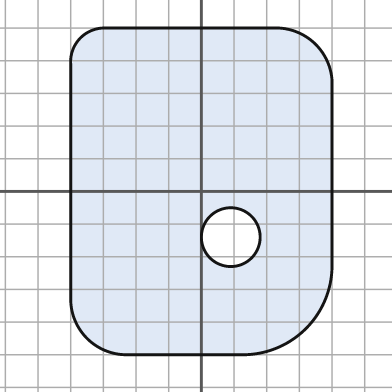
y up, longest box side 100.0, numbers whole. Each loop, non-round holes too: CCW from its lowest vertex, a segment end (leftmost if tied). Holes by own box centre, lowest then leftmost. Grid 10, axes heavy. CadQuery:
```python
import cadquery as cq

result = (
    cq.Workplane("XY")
    .moveTo(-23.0, -50.0)
    .lineTo(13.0, -50.0)
    .threePointArc((32.0, -42.0), (40.0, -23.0))
    .lineTo(40.0, 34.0)
    .threePointArc((35.0, 45.0), (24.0, 50.0))
    .lineTo(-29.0, 50.0)
    .threePointArc((-37.0, 47.0), (-40.0, 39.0))
    .lineTo(-40.0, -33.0)
    .threePointArc((-35.0, -45.0), (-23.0, -50.0))
    .close()
    .moveTo(9.0, -14.0)
    .circle(9.0)
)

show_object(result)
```